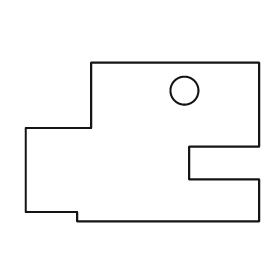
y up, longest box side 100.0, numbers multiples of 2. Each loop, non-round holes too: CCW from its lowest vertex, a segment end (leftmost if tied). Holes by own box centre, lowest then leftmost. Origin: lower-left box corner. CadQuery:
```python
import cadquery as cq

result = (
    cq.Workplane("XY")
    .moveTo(22.0, 0.0)
    .lineTo(100.0, 0.0)
    .lineTo(100.0, 18.0)
    .lineTo(70.0, 18.0)
    .lineTo(70.0, 32.0)
    .lineTo(100.0, 32.0)
    .lineTo(100.0, 68.0)
    .lineTo(28.0, 68.0)
    .lineTo(28.0, 40.0)
    .lineTo(0.0, 40.0)
    .lineTo(0.0, 4.0)
    .lineTo(22.0, 4.0)
    .close()
    .moveTo(68.0, 56.0)
    .circle(6.0)
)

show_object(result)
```